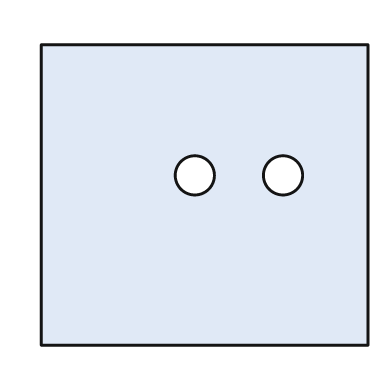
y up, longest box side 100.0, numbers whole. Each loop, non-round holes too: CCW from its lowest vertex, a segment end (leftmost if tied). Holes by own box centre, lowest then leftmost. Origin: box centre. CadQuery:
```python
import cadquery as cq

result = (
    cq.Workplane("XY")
    .moveTo(-50.0, -46.0)
    .lineTo(50.0, -46.0)
    .lineTo(50.0, 46.0)
    .lineTo(-50.0, 46.0)
    .close()
    .moveTo(-3.0, 6.0)
    .circle(6.0)
    .moveTo(24.0, 6.0)
    .circle(6.0)
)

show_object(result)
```